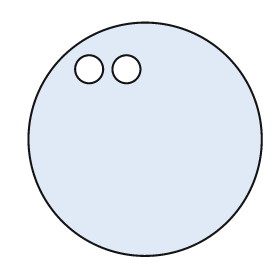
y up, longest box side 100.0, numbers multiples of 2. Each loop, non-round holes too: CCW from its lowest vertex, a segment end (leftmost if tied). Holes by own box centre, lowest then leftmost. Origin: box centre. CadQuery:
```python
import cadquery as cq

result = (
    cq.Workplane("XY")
    .moveTo(0.0, 0.0)
    .circle(50.0)
    .moveTo(-24.0, 30.0)
    .circle(6.0)
    .moveTo(-8.0, 30.0)
    .circle(6.0)
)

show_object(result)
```